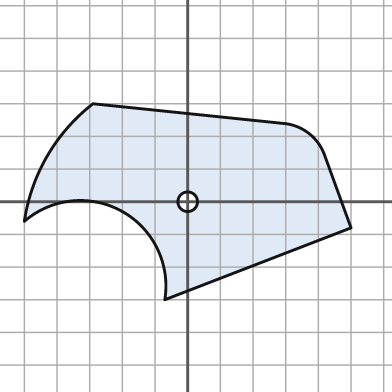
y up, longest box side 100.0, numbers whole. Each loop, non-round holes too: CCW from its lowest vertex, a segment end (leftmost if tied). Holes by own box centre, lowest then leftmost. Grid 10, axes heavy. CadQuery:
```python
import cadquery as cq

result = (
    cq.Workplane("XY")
    .moveTo(-7.0, -30.0)
    .lineTo(50.0, -8.0)
    .lineTo(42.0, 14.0)
    .threePointArc((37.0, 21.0), (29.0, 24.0))
    .lineTo(-29.0, 30.0)
    .threePointArc((-43.0, 14.0), (-50.0, -6.0))
    .threePointArc((-20.0, -3.0), (-7.0, -30.0))
    .close()
    .moveTo(0.0, 0.0)
    .circle(3.0)
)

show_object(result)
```